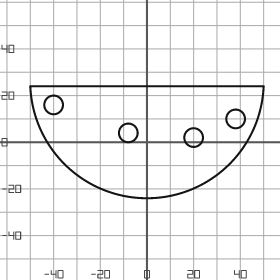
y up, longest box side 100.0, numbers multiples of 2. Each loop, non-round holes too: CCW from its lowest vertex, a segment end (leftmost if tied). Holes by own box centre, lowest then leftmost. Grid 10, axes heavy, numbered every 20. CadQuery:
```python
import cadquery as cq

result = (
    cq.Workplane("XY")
    .moveTo(-50.0, 24.0)
    .threePointArc((0.0, -24.0), (50.0, 24.0))
    .close()
    .moveTo(20.0, 2.0)
    .circle(4.0)
    .moveTo(-8.0, 4.0)
    .circle(4.0)
    .moveTo(38.0, 10.0)
    .circle(4.0)
    .moveTo(-40.0, 16.0)
    .circle(4.0)
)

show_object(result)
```